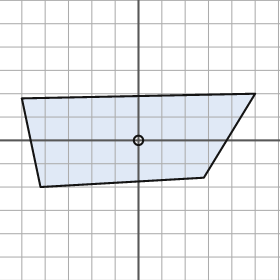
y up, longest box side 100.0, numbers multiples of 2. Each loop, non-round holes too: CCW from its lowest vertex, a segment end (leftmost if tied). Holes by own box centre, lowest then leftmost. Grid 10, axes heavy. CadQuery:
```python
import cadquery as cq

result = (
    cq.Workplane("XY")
    .moveTo(-42.0, -20.0)
    .lineTo(28.0, -16.0)
    .lineTo(50.0, 20.0)
    .lineTo(-50.0, 18.0)
    .close()
    .moveTo(0.0, 0.0)
    .circle(2.0)
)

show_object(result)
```